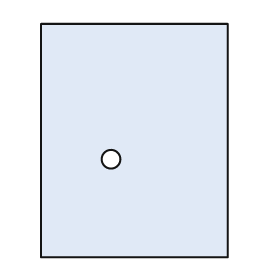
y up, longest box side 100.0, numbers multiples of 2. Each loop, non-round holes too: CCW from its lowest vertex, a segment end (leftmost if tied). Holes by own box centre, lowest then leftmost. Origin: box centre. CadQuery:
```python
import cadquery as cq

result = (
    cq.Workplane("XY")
    .moveTo(-40.0, -50.0)
    .lineTo(40.0, -50.0)
    .lineTo(40.0, 50.0)
    .lineTo(-40.0, 50.0)
    .close()
    .moveTo(-10.0, -8.0)
    .circle(4.0)
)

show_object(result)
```